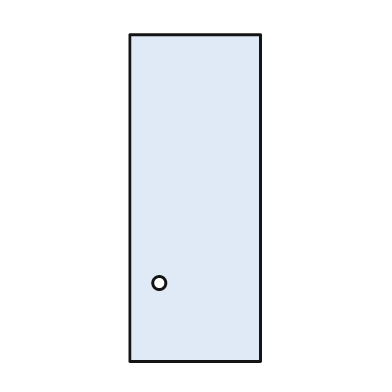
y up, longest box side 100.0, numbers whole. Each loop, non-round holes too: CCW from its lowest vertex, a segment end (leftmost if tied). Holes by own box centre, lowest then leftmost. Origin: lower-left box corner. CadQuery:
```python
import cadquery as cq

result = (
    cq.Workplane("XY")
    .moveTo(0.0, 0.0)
    .lineTo(40.0, 0.0)
    .lineTo(40.0, 100.0)
    .lineTo(0.0, 100.0)
    .close()
    .moveTo(9.0, 24.0)
    .circle(2.0)
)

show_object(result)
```